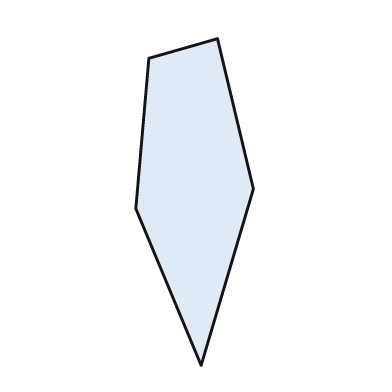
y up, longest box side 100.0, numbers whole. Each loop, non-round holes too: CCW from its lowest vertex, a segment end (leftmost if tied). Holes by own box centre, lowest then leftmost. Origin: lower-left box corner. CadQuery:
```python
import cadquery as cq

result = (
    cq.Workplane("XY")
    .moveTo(20.0, 0.0)
    .lineTo(36.0, 54.0)
    .lineTo(25.0, 100.0)
    .lineTo(4.0, 94.0)
    .lineTo(0.0, 48.0)
    .close()
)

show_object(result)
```